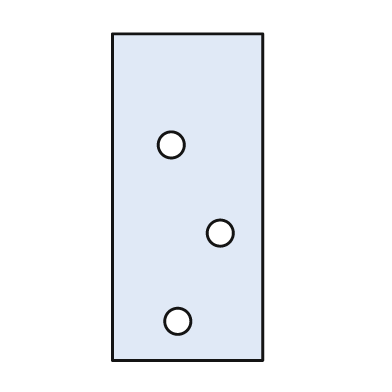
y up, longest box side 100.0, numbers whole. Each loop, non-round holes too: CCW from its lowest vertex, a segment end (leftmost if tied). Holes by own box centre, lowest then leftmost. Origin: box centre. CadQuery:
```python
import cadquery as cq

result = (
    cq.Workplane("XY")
    .moveTo(-23.0, -50.0)
    .lineTo(23.0, -50.0)
    .lineTo(23.0, 50.0)
    .lineTo(-23.0, 50.0)
    .close()
    .moveTo(-3.0, -38.0)
    .circle(4.0)
    .moveTo(10.0, -11.0)
    .circle(4.0)
    .moveTo(-5.0, 16.0)
    .circle(4.0)
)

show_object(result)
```